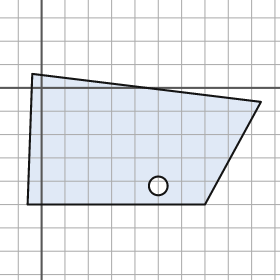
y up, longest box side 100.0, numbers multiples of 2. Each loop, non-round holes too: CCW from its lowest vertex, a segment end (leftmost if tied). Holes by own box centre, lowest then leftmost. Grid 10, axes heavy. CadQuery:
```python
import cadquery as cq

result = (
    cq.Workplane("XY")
    .moveTo(-6.0, -50.0)
    .lineTo(70.0, -50.0)
    .lineTo(94.0, -6.0)
    .lineTo(-4.0, 6.0)
    .close()
    .moveTo(50.0, -42.0)
    .circle(4.0)
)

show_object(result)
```